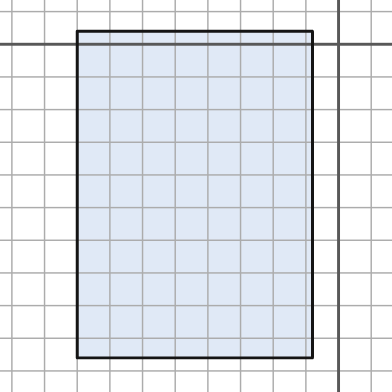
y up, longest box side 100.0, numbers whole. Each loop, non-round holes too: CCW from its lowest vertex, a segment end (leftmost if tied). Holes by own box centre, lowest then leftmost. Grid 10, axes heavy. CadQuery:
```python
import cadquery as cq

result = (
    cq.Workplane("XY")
    .moveTo(-80.0, -96.0)
    .lineTo(-8.0, -96.0)
    .lineTo(-8.0, 4.0)
    .lineTo(-80.0, 4.0)
    .close()
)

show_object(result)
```